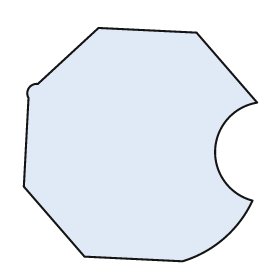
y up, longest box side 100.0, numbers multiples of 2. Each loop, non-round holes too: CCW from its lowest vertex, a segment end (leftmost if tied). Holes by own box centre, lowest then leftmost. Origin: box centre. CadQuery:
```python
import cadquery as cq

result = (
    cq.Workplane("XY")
    .moveTo(18.0, -50.0)
    .threePointArc((36.0, -40.0), (48.0, -24.0))
    .threePointArc((32.0, -2.0), (50.0, 18.0))
    .lineTo(24.0, 48.0)
    .lineTo(-18.0, 50.0)
    .lineTo(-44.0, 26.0)
    .threePointArc((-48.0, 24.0), (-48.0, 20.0))
    .lineTo(-50.0, -18.0)
    .lineTo(-24.0, -48.0)
    .close()
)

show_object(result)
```